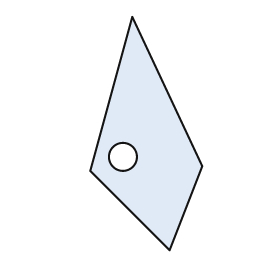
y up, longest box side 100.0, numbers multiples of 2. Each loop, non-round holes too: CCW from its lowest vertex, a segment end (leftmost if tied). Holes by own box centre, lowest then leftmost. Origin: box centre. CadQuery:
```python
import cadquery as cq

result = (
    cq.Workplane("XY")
    .moveTo(10.0, -50.0)
    .lineTo(24.0, -14.0)
    .lineTo(-6.0, 50.0)
    .lineTo(-24.0, -16.0)
    .close()
    .moveTo(-10.0, -10.0)
    .circle(6.0)
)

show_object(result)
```